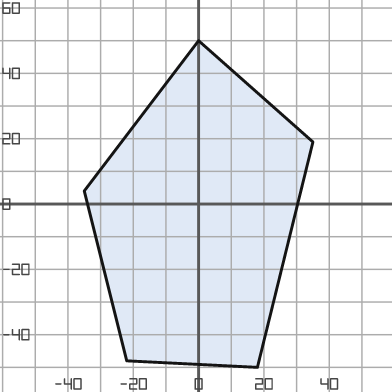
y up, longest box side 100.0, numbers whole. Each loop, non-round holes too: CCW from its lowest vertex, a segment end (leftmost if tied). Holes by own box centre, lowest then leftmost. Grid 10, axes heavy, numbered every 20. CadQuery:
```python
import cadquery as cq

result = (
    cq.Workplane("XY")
    .moveTo(18.0, -50.0)
    .lineTo(35.0, 19.0)
    .lineTo(0.0, 50.0)
    .lineTo(-35.0, 4.0)
    .lineTo(-22.0, -48.0)
    .close()
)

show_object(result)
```